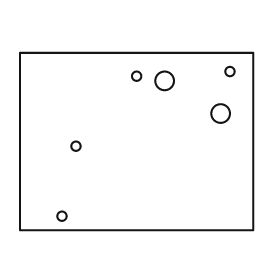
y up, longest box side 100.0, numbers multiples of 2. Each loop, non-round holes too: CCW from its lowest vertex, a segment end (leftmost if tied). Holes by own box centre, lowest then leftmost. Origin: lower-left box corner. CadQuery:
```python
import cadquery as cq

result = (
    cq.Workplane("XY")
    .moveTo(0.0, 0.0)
    .lineTo(100.0, 0.0)
    .lineTo(100.0, 76.0)
    .lineTo(0.0, 76.0)
    .close()
    .moveTo(18.0, 6.0)
    .circle(2.0)
    .moveTo(24.0, 36.0)
    .circle(2.0)
    .moveTo(86.0, 50.0)
    .circle(4.0)
    .moveTo(62.0, 64.0)
    .circle(4.0)
    .moveTo(50.0, 66.0)
    .circle(2.0)
    .moveTo(90.0, 68.0)
    .circle(2.0)
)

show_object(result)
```